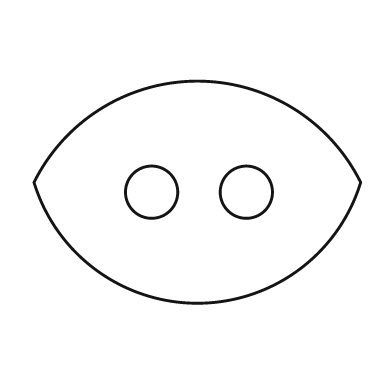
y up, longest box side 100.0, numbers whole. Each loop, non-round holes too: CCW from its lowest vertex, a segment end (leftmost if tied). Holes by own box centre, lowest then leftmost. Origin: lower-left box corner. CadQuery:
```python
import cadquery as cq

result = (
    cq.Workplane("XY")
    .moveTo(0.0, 37.0)
    .threePointArc((50.0, 0.0), (100.0, 37.0))
    .threePointArc((50.0, 68.0), (0.0, 37.0))
    .close()
    .moveTo(36.0, 34.0)
    .circle(8.0)
    .moveTo(65.0, 34.0)
    .circle(8.0)
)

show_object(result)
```